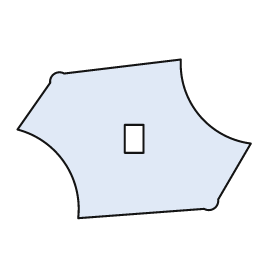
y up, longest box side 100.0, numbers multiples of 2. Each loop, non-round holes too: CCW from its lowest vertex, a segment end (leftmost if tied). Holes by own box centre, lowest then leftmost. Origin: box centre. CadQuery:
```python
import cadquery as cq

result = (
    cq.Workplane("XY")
    .moveTo(-24.0, -34.0)
    .lineTo(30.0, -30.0)
    .threePointArc((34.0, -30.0), (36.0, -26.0))
    .lineTo(50.0, -2.0)
    .threePointArc((28.0, 10.0), (20.0, 34.0))
    .lineTo(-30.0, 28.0)
    .threePointArc((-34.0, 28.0), (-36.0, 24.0))
    .lineTo(-50.0, 4.0)
    .threePointArc((-30.0, -10.0), (-24.0, -34.0))
    .close()
    .moveTo(-4.0, -6.0)
    .lineTo(4.0, -6.0)
    .lineTo(4.0, 6.0)
    .lineTo(-4.0, 6.0)
    .close()
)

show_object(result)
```